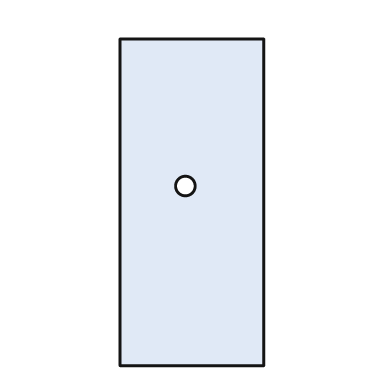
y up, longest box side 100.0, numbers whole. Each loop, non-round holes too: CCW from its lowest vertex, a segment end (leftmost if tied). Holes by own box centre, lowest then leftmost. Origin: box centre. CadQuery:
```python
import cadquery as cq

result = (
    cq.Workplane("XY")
    .moveTo(-22.0, -50.0)
    .lineTo(22.0, -50.0)
    .lineTo(22.0, 50.0)
    .lineTo(-22.0, 50.0)
    .close()
    .moveTo(-2.0, 5.0)
    .circle(3.0)
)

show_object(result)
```